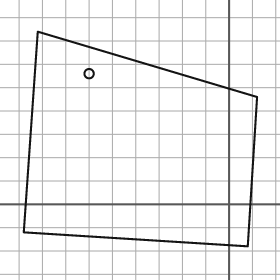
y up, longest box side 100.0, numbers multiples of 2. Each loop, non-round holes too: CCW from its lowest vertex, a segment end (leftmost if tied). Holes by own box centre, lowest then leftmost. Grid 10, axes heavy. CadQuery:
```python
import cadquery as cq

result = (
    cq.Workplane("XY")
    .moveTo(8.0, -18.0)
    .lineTo(12.0, 46.0)
    .lineTo(-82.0, 74.0)
    .lineTo(-88.0, -12.0)
    .close()
    .moveTo(-60.0, 56.0)
    .circle(2.0)
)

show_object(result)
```